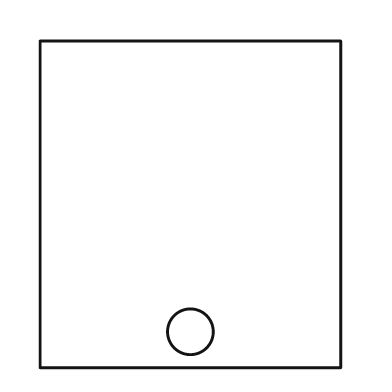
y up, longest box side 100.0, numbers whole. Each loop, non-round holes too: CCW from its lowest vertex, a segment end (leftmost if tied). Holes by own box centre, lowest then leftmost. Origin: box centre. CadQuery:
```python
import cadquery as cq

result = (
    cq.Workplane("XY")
    .moveTo(-46.0, -50.0)
    .lineTo(46.0, -50.0)
    .lineTo(46.0, 50.0)
    .lineTo(-46.0, 50.0)
    .close()
    .moveTo(0.0, -39.0)
    .circle(7.0)
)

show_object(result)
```